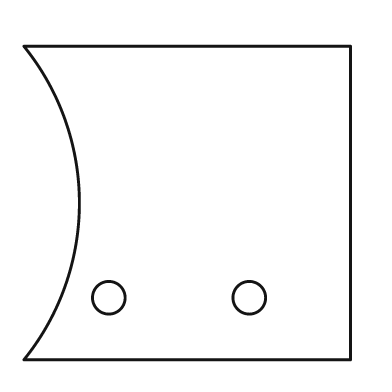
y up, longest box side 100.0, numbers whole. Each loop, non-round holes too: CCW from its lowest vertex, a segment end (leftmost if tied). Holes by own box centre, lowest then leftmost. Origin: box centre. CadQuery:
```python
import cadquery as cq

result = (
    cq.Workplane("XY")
    .moveTo(-50.0, -48.0)
    .lineTo(50.0, -48.0)
    .lineTo(50.0, 48.0)
    .lineTo(-50.0, 48.0)
    .threePointArc((-33.0, 0.0), (-50.0, -48.0))
    .close()
    .moveTo(-24.0, -29.0)
    .circle(5.0)
    .moveTo(19.0, -29.0)
    .circle(5.0)
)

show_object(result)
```